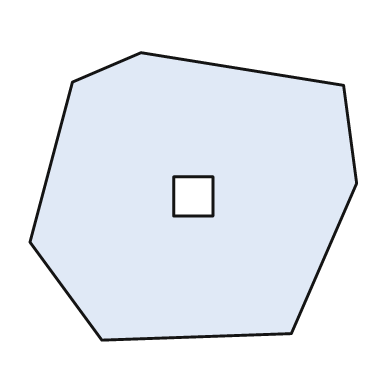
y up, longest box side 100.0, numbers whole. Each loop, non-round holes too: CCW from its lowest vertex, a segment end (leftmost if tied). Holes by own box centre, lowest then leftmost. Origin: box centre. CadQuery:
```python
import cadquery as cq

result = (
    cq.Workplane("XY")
    .moveTo(-28.0, -44.0)
    .lineTo(30.0, -42.0)
    .lineTo(50.0, 4.0)
    .lineTo(46.0, 34.0)
    .lineTo(-16.0, 44.0)
    .lineTo(-37.0, 35.0)
    .lineTo(-50.0, -14.0)
    .close()
    .moveTo(-6.0, -6.0)
    .lineTo(6.0, -6.0)
    .lineTo(6.0, 6.0)
    .lineTo(-6.0, 6.0)
    .close()
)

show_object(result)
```